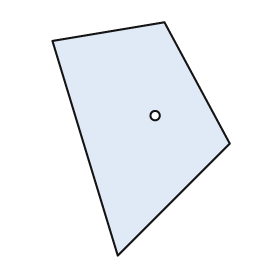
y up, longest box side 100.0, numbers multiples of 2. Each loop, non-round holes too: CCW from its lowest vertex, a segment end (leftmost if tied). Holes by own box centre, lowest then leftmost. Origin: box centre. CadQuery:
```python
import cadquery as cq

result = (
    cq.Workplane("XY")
    .moveTo(-10.0, -50.0)
    .lineTo(38.0, -2.0)
    .lineTo(10.0, 50.0)
    .lineTo(-38.0, 42.0)
    .close()
    .moveTo(6.0, 10.0)
    .circle(2.0)
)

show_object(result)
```